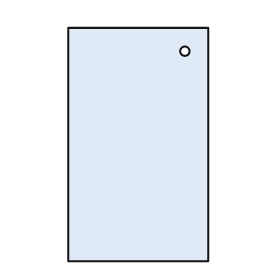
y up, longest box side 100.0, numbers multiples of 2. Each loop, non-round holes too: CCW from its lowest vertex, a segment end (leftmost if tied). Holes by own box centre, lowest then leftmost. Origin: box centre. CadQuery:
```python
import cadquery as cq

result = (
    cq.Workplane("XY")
    .moveTo(-30.0, -50.0)
    .lineTo(30.0, -50.0)
    .lineTo(30.0, 50.0)
    .lineTo(-30.0, 50.0)
    .close()
    .moveTo(20.0, 40.0)
    .circle(2.0)
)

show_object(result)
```